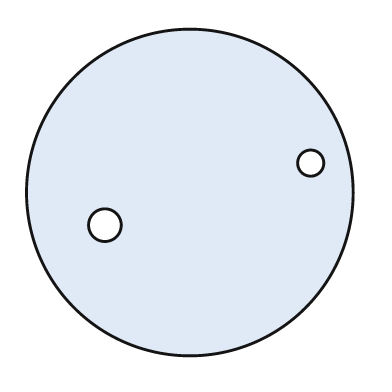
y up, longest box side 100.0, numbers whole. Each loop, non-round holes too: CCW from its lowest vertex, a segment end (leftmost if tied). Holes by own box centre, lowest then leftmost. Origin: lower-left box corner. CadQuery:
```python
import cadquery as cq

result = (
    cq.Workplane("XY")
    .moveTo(50.0, 50.0)
    .circle(50.0)
    .moveTo(24.0, 40.0)
    .circle(5.0)
    .moveTo(87.0, 59.0)
    .circle(4.0)
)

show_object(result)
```